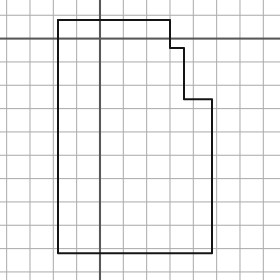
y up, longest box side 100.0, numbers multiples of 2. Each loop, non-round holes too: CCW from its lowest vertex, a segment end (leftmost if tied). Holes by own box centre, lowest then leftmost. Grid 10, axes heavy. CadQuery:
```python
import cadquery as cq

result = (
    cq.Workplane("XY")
    .moveTo(-18.0, -92.0)
    .lineTo(48.0, -92.0)
    .lineTo(48.0, -26.0)
    .lineTo(36.0, -26.0)
    .lineTo(36.0, -4.0)
    .lineTo(30.0, -4.0)
    .lineTo(30.0, 8.0)
    .lineTo(-18.0, 8.0)
    .close()
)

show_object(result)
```